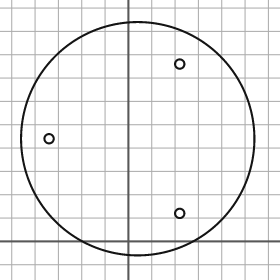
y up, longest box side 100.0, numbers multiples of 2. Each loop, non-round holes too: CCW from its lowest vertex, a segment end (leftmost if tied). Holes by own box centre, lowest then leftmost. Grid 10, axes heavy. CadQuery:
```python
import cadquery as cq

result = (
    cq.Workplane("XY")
    .moveTo(4.0, 44.0)
    .circle(50.0)
    .moveTo(22.0, 12.0)
    .circle(2.0)
    .moveTo(-34.0, 44.0)
    .circle(2.0)
    .moveTo(22.0, 76.0)
    .circle(2.0)
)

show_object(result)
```